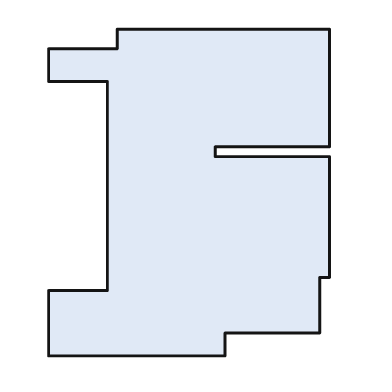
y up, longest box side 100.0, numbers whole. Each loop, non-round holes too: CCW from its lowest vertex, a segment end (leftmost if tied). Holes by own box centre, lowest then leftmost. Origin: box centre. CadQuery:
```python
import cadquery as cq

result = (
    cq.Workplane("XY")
    .moveTo(-43.0, -50.0)
    .lineTo(11.0, -50.0)
    .lineTo(11.0, -43.0)
    .lineTo(40.0, -43.0)
    .lineTo(40.0, -26.0)
    .lineTo(43.0, -26.0)
    .lineTo(43.0, 11.0)
    .lineTo(8.0, 11.0)
    .lineTo(8.0, 14.0)
    .lineTo(43.0, 14.0)
    .lineTo(43.0, 50.0)
    .lineTo(-22.0, 50.0)
    .lineTo(-22.0, 44.0)
    .lineTo(-43.0, 44.0)
    .lineTo(-43.0, 34.0)
    .lineTo(-25.0, 34.0)
    .lineTo(-25.0, -30.0)
    .lineTo(-43.0, -30.0)
    .close()
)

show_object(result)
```